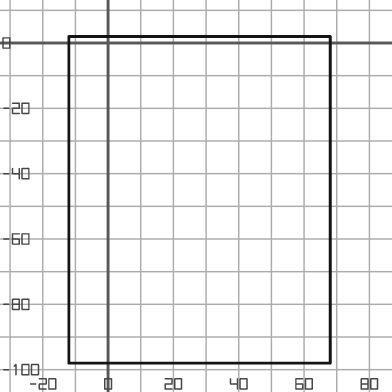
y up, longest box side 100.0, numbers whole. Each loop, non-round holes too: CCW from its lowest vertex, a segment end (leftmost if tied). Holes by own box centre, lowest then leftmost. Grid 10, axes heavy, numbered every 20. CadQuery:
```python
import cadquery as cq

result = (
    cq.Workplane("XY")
    .moveTo(-12.0, -98.0)
    .lineTo(68.0, -98.0)
    .lineTo(68.0, 2.0)
    .lineTo(-12.0, 2.0)
    .close()
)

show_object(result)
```